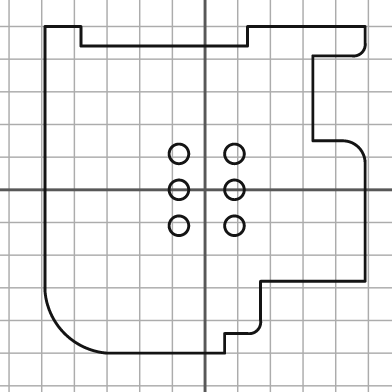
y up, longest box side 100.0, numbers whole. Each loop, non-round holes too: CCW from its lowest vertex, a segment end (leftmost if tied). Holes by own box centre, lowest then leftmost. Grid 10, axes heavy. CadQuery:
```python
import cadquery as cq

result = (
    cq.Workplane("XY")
    .moveTo(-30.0, -50.0)
    .lineTo(6.0, -50.0)
    .lineTo(6.0, -44.0)
    .lineTo(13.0, -44.0)
    .threePointArc((16.0, -43.0), (17.0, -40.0))
    .lineTo(17.0, -28.0)
    .lineTo(49.0, -28.0)
    .lineTo(49.0, 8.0)
    .threePointArc((47.0, 13.0), (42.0, 15.0))
    .lineTo(33.0, 15.0)
    .lineTo(33.0, 41.0)
    .lineTo(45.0, 41.0)
    .threePointArc((48.0, 42.0), (49.0, 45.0))
    .lineTo(49.0, 50.0)
    .lineTo(13.0, 50.0)
    .lineTo(13.0, 44.0)
    .lineTo(-38.0, 44.0)
    .lineTo(-38.0, 50.0)
    .lineTo(-49.0, 50.0)
    .lineTo(-49.0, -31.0)
    .threePointArc((-43.0, -44.0), (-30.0, -50.0))
    .close()
    .moveTo(-8.0, -11.0)
    .circle(3.0)
    .moveTo(9.0, -11.0)
    .circle(3.0)
    .moveTo(-8.0, 0.0)
    .circle(3.0)
    .moveTo(9.0, 0.0)
    .circle(3.0)
    .moveTo(-8.0, 11.0)
    .circle(3.0)
    .moveTo(9.0, 11.0)
    .circle(3.0)
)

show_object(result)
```